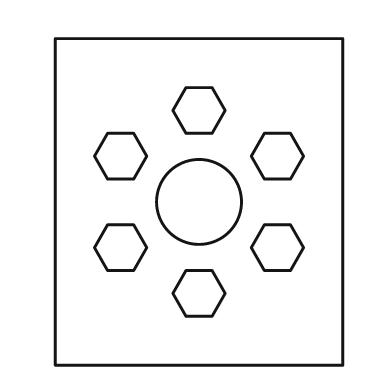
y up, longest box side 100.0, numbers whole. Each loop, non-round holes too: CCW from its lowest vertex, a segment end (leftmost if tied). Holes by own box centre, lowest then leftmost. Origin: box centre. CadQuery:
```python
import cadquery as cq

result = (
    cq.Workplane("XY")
    .moveTo(-44.0, -50.0)
    .lineTo(44.0, -50.0)
    .lineTo(44.0, 50.0)
    .lineTo(-44.0, 50.0)
    .close()
    .moveTo(-4.0, -35.0)
    .lineTo(4.0, -35.0)
    .lineTo(8.0, -28.0)
    .lineTo(4.0, -21.0)
    .lineTo(-4.0, -21.0)
    .lineTo(-8.0, -28.0)
    .close()
    .moveTo(-28.0, -21.0)
    .lineTo(-20.0, -21.0)
    .lineTo(-16.0, -14.0)
    .lineTo(-20.0, -7.0)
    .lineTo(-28.0, -7.0)
    .lineTo(-32.0, -14.0)
    .close()
    .moveTo(20.0, -21.0)
    .lineTo(28.0, -21.0)
    .lineTo(32.0, -14.0)
    .lineTo(28.0, -7.0)
    .lineTo(20.0, -7.0)
    .lineTo(16.0, -14.0)
    .close()
    .moveTo(0.0, 0.0)
    .circle(13.0)
    .moveTo(-28.0, 7.0)
    .lineTo(-20.0, 7.0)
    .lineTo(-16.0, 14.0)
    .lineTo(-20.0, 21.0)
    .lineTo(-28.0, 21.0)
    .lineTo(-32.0, 14.0)
    .close()
    .moveTo(20.0, 7.0)
    .lineTo(28.0, 7.0)
    .lineTo(32.0, 14.0)
    .lineTo(28.0, 21.0)
    .lineTo(20.0, 21.0)
    .lineTo(16.0, 14.0)
    .close()
    .moveTo(-4.0, 21.0)
    .lineTo(4.0, 21.0)
    .lineTo(8.0, 28.0)
    .lineTo(4.0, 35.0)
    .lineTo(-4.0, 35.0)
    .lineTo(-8.0, 28.0)
    .close()
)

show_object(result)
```